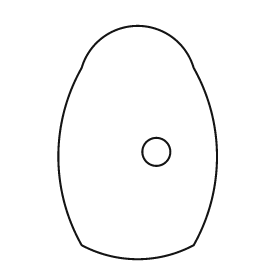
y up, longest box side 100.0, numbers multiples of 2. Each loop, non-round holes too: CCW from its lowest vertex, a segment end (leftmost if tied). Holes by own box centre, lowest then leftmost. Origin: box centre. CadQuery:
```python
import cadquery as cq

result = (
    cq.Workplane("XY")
    .moveTo(-24.0, -44.0)
    .threePointArc((0.0, -50.0), (24.0, -44.0))
    .threePointArc((34.0, -6.0), (24.0, 32.0))
    .threePointArc((0.0, 50.0), (-24.0, 32.0))
    .threePointArc((-34.0, -6.0), (-24.0, -44.0))
    .close()
    .moveTo(8.0, -4.0)
    .circle(6.0)
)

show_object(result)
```